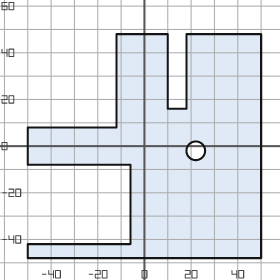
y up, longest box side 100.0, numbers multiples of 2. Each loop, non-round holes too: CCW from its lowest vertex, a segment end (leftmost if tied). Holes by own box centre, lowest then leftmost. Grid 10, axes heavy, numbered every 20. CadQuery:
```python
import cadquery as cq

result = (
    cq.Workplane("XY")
    .moveTo(-50.0, -48.0)
    .lineTo(50.0, -48.0)
    .lineTo(50.0, 48.0)
    .lineTo(18.0, 48.0)
    .lineTo(18.0, 16.0)
    .lineTo(10.0, 16.0)
    .lineTo(10.0, 48.0)
    .lineTo(-12.0, 48.0)
    .lineTo(-12.0, 8.0)
    .lineTo(-50.0, 8.0)
    .lineTo(-50.0, -8.0)
    .lineTo(-6.0, -8.0)
    .lineTo(-6.0, -42.0)
    .lineTo(-50.0, -42.0)
    .close()
    .moveTo(22.0, -2.0)
    .circle(4.0)
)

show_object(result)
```